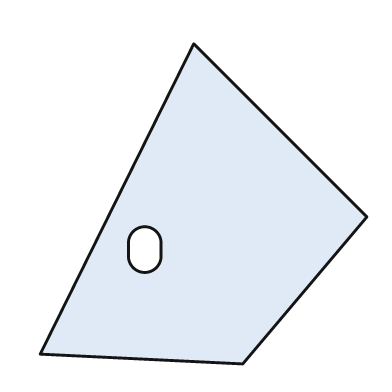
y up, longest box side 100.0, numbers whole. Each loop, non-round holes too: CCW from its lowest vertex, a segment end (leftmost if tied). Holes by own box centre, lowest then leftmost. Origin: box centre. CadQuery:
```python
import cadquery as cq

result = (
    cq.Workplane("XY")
    .moveTo(12.0, -49.0)
    .lineTo(50.0, -4.0)
    .lineTo(-3.0, 49.0)
    .lineTo(-50.0, -46.0)
    .close()
    .moveTo(-23.0, -16.0)
    .threePointArc((-18.0, -21.0), (-13.0, -16.0))
    .lineTo(-13.0, -12.0)
    .threePointArc((-18.0, -7.0), (-23.0, -12.0))
    .close()
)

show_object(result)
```